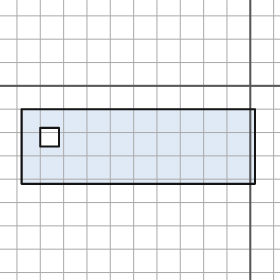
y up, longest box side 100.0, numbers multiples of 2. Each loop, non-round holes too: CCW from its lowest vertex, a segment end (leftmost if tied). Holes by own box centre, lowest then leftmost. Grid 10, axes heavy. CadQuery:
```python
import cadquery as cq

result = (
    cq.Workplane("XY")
    .moveTo(-98.0, -42.0)
    .lineTo(2.0, -42.0)
    .lineTo(2.0, -10.0)
    .lineTo(-98.0, -10.0)
    .close()
    .moveTo(-90.0, -26.0)
    .lineTo(-82.0, -26.0)
    .lineTo(-82.0, -18.0)
    .lineTo(-90.0, -18.0)
    .close()
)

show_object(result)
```